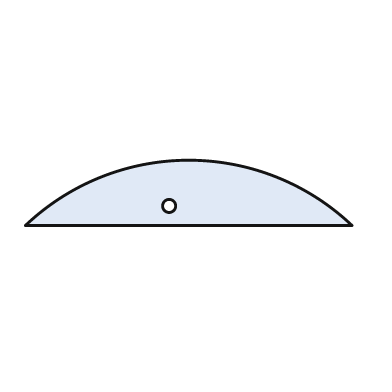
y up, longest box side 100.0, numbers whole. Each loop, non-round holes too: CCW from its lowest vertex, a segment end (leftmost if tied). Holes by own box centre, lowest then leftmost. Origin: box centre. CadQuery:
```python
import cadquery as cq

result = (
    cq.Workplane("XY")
    .moveTo(-50.0, -10.0)
    .lineTo(50.0, -10.0)
    .threePointArc((0.0, 10.0), (-50.0, -10.0))
    .close()
    .moveTo(-6.0, -4.0)
    .circle(2.0)
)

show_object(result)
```